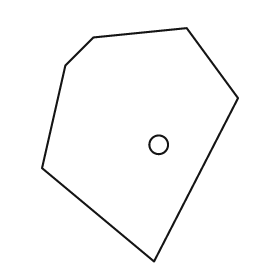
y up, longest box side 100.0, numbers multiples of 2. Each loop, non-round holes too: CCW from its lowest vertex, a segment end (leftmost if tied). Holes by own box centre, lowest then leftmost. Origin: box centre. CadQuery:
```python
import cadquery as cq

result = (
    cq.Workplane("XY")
    .moveTo(6.0, -50.0)
    .lineTo(42.0, 20.0)
    .lineTo(20.0, 50.0)
    .lineTo(-20.0, 46.0)
    .lineTo(-32.0, 34.0)
    .lineTo(-42.0, -10.0)
    .close()
    .moveTo(8.0, 0.0)
    .circle(4.0)
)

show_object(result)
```